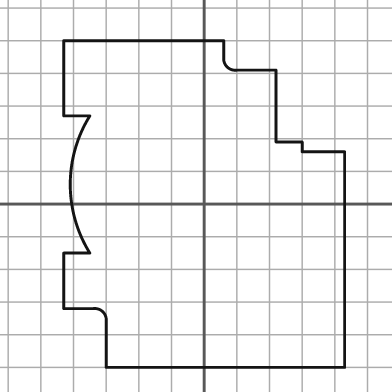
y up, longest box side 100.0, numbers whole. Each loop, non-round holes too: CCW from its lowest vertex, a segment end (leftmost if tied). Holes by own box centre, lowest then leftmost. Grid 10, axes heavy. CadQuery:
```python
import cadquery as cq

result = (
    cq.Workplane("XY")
    .moveTo(-30.0, -50.0)
    .lineTo(43.0, -50.0)
    .lineTo(43.0, 16.0)
    .lineTo(30.0, 16.0)
    .lineTo(30.0, 19.0)
    .lineTo(22.0, 19.0)
    .lineTo(22.0, 41.0)
    .lineTo(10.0, 41.0)
    .threePointArc((7.0, 42.0), (6.0, 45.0))
    .lineTo(6.0, 50.0)
    .lineTo(-43.0, 50.0)
    .lineTo(-43.0, 27.0)
    .lineTo(-35.0, 27.0)
    .threePointArc((-41.0, 6.0), (-35.0, -15.0))
    .lineTo(-43.0, -15.0)
    .lineTo(-43.0, -32.0)
    .lineTo(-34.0, -32.0)
    .threePointArc((-31.0, -33.0), (-30.0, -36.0))
    .close()
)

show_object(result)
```